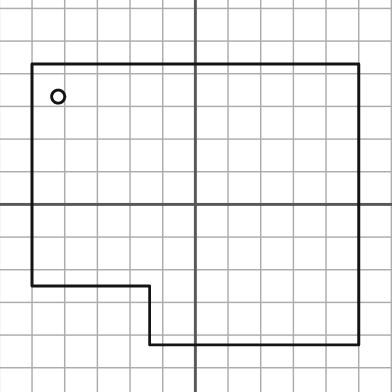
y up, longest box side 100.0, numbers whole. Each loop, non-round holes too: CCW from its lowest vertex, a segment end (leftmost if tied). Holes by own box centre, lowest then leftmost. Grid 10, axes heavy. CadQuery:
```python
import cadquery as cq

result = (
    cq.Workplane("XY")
    .moveTo(-14.0, -43.0)
    .lineTo(50.0, -43.0)
    .lineTo(50.0, 43.0)
    .lineTo(-50.0, 43.0)
    .lineTo(-50.0, -25.0)
    .lineTo(-14.0, -25.0)
    .close()
    .moveTo(-42.0, 33.0)
    .circle(2.0)
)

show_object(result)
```